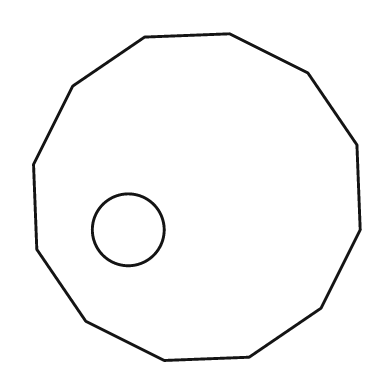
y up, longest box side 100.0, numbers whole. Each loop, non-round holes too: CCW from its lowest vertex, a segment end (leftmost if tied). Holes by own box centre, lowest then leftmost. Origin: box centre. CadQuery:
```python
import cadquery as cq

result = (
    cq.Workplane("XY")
    .moveTo(-10.0, -50.0)
    .lineTo(16.0, -49.0)
    .lineTo(38.0, -34.0)
    .lineTo(50.0, -10.0)
    .lineTo(49.0, 16.0)
    .lineTo(34.0, 38.0)
    .lineTo(10.0, 50.0)
    .lineTo(-16.0, 49.0)
    .lineTo(-38.0, 34.0)
    .lineTo(-50.0, 10.0)
    .lineTo(-49.0, -16.0)
    .lineTo(-34.0, -38.0)
    .close()
    .moveTo(-21.0, -10.0)
    .circle(11.0)
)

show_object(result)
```